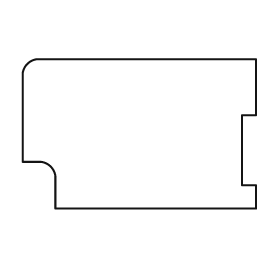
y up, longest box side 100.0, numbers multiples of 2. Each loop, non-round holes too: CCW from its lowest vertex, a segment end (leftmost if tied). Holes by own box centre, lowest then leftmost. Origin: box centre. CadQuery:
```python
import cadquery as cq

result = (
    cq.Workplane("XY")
    .moveTo(-36.0, -32.0)
    .lineTo(50.0, -32.0)
    .lineTo(50.0, -22.0)
    .lineTo(44.0, -22.0)
    .lineTo(44.0, 8.0)
    .lineTo(50.0, 8.0)
    .lineTo(50.0, 32.0)
    .lineTo(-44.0, 32.0)
    .threePointArc((-48.0, 30.0), (-50.0, 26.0))
    .lineTo(-50.0, -12.0)
    .lineTo(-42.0, -12.0)
    .threePointArc((-38.0, -14.0), (-36.0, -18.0))
    .close()
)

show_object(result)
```